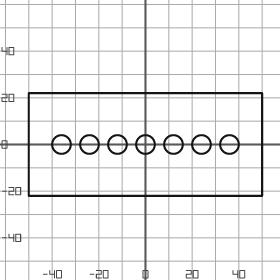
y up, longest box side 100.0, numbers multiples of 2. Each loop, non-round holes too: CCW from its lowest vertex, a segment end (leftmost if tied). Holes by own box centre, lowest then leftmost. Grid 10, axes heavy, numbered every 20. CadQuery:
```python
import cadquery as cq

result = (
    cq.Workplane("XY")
    .moveTo(-50.0, -22.0)
    .lineTo(50.0, -22.0)
    .lineTo(50.0, 22.0)
    .lineTo(-50.0, 22.0)
    .close()
    .moveTo(-36.0, 0.0)
    .circle(4.0)
    .moveTo(-24.0, 0.0)
    .circle(4.0)
    .moveTo(-12.0, 0.0)
    .circle(4.0)
    .moveTo(0.0, 0.0)
    .circle(4.0)
    .moveTo(12.0, 0.0)
    .circle(4.0)
    .moveTo(24.0, 0.0)
    .circle(4.0)
    .moveTo(36.0, 0.0)
    .circle(4.0)
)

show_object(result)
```